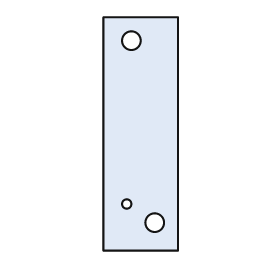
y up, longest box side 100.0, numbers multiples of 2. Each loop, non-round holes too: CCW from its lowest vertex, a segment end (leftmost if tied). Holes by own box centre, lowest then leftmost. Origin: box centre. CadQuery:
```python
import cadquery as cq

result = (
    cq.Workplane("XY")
    .moveTo(-16.0, -50.0)
    .lineTo(16.0, -50.0)
    .lineTo(16.0, 50.0)
    .lineTo(-16.0, 50.0)
    .close()
    .moveTo(6.0, -38.0)
    .circle(4.0)
    .moveTo(-6.0, -30.0)
    .circle(2.0)
    .moveTo(-4.0, 40.0)
    .circle(4.0)
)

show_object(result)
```